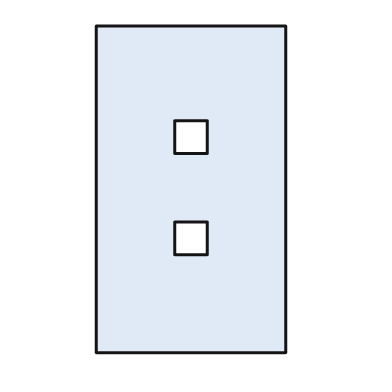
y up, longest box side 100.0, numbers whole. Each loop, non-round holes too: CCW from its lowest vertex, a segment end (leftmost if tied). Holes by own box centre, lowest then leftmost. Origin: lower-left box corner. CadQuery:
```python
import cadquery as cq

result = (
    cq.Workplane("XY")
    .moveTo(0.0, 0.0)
    .lineTo(58.0, 0.0)
    .lineTo(58.0, 100.0)
    .lineTo(0.0, 100.0)
    .close()
    .moveTo(24.0, 30.0)
    .lineTo(34.0, 30.0)
    .lineTo(34.0, 40.0)
    .lineTo(24.0, 40.0)
    .close()
    .moveTo(24.0, 61.0)
    .lineTo(34.0, 61.0)
    .lineTo(34.0, 71.0)
    .lineTo(24.0, 71.0)
    .close()
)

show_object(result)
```